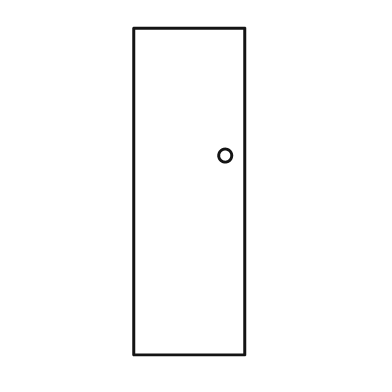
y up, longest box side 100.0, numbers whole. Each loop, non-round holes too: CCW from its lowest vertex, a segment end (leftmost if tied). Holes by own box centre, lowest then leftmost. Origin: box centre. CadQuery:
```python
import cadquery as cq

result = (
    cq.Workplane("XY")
    .moveTo(-17.0, -50.0)
    .lineTo(17.0, -50.0)
    .lineTo(17.0, 50.0)
    .lineTo(-17.0, 50.0)
    .close()
    .moveTo(11.0, 11.0)
    .circle(2.0)
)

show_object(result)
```